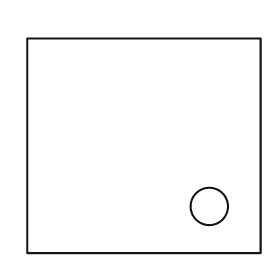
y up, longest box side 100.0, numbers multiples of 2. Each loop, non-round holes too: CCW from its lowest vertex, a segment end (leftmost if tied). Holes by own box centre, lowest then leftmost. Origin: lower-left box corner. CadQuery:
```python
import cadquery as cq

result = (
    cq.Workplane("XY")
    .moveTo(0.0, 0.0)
    .lineTo(100.0, 0.0)
    .lineTo(100.0, 92.0)
    .lineTo(0.0, 92.0)
    .close()
    .moveTo(78.0, 20.0)
    .circle(8.0)
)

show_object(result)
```